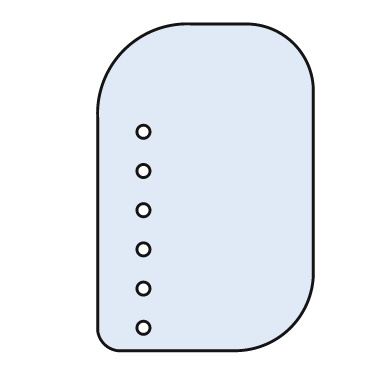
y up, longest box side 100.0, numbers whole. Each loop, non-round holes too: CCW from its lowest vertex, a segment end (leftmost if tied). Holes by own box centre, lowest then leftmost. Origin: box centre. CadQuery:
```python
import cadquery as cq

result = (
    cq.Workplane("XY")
    .moveTo(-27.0, -50.0)
    .lineTo(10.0, -50.0)
    .threePointArc((26.0, -43.0), (33.0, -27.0))
    .lineTo(33.0, 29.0)
    .threePointArc((27.0, 44.0), (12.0, 50.0))
    .lineTo(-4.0, 50.0)
    .threePointArc((-25.0, 42.0), (-33.0, 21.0))
    .lineTo(-33.0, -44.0)
    .threePointArc((-31.0, -48.0), (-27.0, -50.0))
    .close()
    .moveTo(-19.0, -43.0)
    .circle(2.0)
    .moveTo(-19.0, -31.0)
    .circle(2.0)
    .moveTo(-19.0, -19.0)
    .circle(2.0)
    .moveTo(-19.0, -7.0)
    .circle(2.0)
    .moveTo(-19.0, 5.0)
    .circle(2.0)
    .moveTo(-19.0, 17.0)
    .circle(2.0)
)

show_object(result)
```